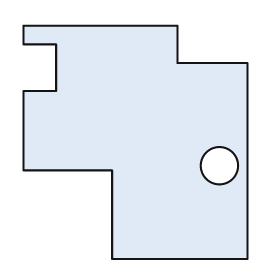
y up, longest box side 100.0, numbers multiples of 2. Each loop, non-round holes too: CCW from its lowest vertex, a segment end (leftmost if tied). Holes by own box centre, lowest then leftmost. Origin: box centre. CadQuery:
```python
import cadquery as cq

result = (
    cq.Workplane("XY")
    .moveTo(-10.0, -50.0)
    .lineTo(48.0, -50.0)
    .lineTo(48.0, 34.0)
    .lineTo(18.0, 34.0)
    .lineTo(18.0, 50.0)
    .lineTo(-48.0, 50.0)
    .lineTo(-48.0, 42.0)
    .lineTo(-34.0, 42.0)
    .lineTo(-34.0, 22.0)
    .lineTo(-48.0, 22.0)
    .lineTo(-48.0, -12.0)
    .lineTo(-10.0, -12.0)
    .close()
    .moveTo(36.0, -10.0)
    .circle(8.0)
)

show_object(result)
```